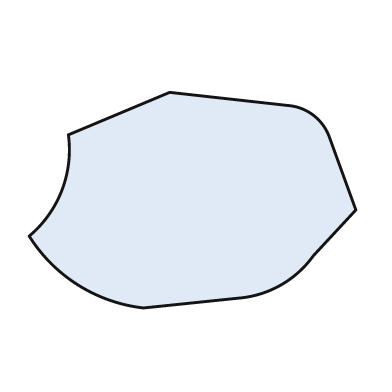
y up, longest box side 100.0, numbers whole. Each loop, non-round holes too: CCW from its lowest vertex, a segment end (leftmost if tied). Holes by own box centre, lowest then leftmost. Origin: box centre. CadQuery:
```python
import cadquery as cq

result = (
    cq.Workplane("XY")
    .moveTo(-15.0, -33.0)
    .lineTo(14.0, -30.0)
    .threePointArc((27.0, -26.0), (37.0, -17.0))
    .lineTo(50.0, -3.0)
    .lineTo(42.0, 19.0)
    .threePointArc((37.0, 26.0), (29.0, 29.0))
    .lineTo(-7.0, 33.0)
    .lineTo(-38.0, 20.0)
    .threePointArc((-40.0, 3.0), (-50.0, -11.0))
    .threePointArc((-35.0, -26.0), (-15.0, -33.0))
    .close()
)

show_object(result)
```